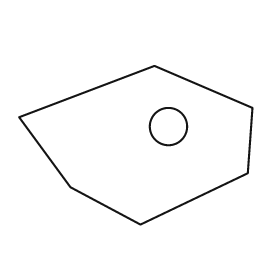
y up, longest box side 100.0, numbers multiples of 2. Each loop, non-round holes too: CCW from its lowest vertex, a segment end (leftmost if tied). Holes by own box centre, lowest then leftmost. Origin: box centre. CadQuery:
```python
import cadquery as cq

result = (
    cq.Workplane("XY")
    .moveTo(2.0, -34.0)
    .lineTo(48.0, -12.0)
    .lineTo(50.0, 16.0)
    .lineTo(8.0, 34.0)
    .lineTo(-50.0, 12.0)
    .lineTo(-28.0, -18.0)
    .close()
    .moveTo(14.0, 8.0)
    .circle(8.0)
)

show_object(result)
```